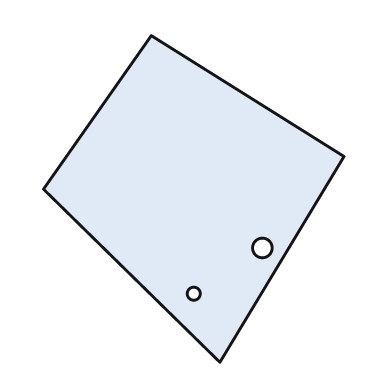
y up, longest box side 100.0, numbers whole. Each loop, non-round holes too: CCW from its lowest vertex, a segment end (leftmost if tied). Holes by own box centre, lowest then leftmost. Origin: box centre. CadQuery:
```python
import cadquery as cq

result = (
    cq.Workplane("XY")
    .moveTo(8.0, -50.0)
    .lineTo(46.0, 13.0)
    .lineTo(-13.0, 50.0)
    .lineTo(-46.0, 3.0)
    .close()
    .moveTo(0.0, -29.0)
    .circle(2.0)
    .moveTo(21.0, -15.0)
    .circle(3.0)
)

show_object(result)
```